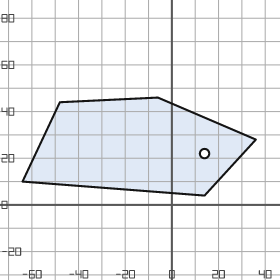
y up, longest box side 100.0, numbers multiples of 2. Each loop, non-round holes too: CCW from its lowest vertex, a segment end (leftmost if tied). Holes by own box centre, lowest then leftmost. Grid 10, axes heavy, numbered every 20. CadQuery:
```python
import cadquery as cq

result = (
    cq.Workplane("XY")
    .moveTo(14.0, 4.0)
    .lineTo(36.0, 28.0)
    .lineTo(-6.0, 46.0)
    .lineTo(-48.0, 44.0)
    .lineTo(-64.0, 10.0)
    .close()
    .moveTo(14.0, 22.0)
    .circle(2.0)
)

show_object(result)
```